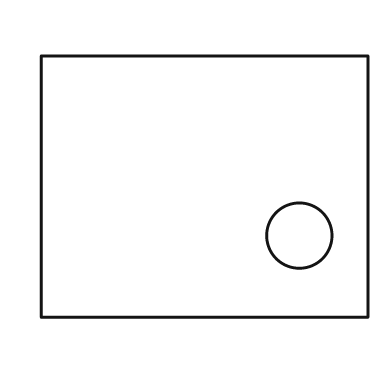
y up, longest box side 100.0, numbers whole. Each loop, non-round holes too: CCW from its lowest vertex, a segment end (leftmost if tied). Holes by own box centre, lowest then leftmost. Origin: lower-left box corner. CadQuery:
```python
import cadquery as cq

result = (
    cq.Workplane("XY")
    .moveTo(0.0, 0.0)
    .lineTo(100.0, 0.0)
    .lineTo(100.0, 80.0)
    .lineTo(0.0, 80.0)
    .close()
    .moveTo(79.0, 25.0)
    .circle(10.0)
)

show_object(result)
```